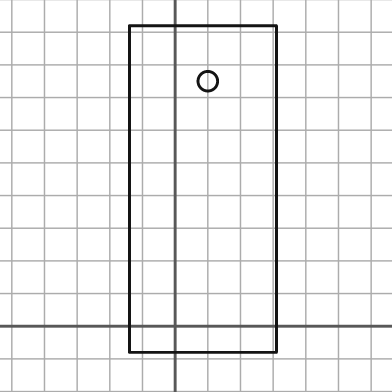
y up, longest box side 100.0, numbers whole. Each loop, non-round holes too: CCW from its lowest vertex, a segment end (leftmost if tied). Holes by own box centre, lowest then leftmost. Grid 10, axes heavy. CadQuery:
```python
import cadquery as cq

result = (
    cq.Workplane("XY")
    .moveTo(-14.0, -8.0)
    .lineTo(31.0, -8.0)
    .lineTo(31.0, 92.0)
    .lineTo(-14.0, 92.0)
    .close()
    .moveTo(10.0, 75.0)
    .circle(3.0)
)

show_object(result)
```